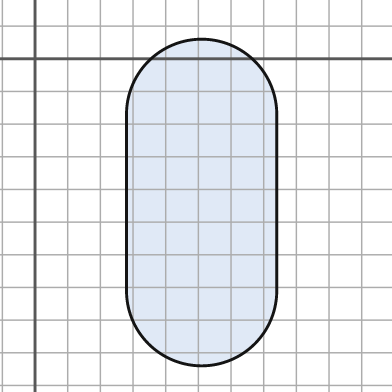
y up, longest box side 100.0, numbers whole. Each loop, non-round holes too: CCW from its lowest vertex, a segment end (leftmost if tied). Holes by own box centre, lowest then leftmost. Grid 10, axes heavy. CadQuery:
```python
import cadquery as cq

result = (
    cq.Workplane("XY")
    .moveTo(28.0, -71.0)
    .threePointArc((51.0, -94.0), (74.0, -71.0))
    .lineTo(74.0, -17.0)
    .threePointArc((51.0, 6.0), (28.0, -17.0))
    .close()
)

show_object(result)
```